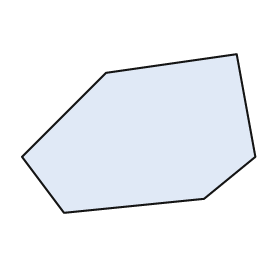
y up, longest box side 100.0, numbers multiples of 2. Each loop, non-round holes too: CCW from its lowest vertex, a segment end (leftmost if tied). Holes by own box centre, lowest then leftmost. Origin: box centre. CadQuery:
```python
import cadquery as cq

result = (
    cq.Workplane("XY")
    .moveTo(-32.0, -34.0)
    .lineTo(28.0, -28.0)
    .lineTo(50.0, -10.0)
    .lineTo(42.0, 34.0)
    .lineTo(-14.0, 26.0)
    .lineTo(-50.0, -10.0)
    .close()
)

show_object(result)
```